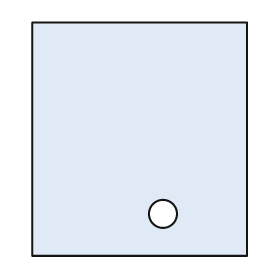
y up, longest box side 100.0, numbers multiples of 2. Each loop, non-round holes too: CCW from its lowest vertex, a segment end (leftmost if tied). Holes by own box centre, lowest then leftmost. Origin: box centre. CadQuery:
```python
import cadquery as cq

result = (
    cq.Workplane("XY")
    .moveTo(-46.0, -50.0)
    .lineTo(46.0, -50.0)
    .lineTo(46.0, 50.0)
    .lineTo(-46.0, 50.0)
    .close()
    .moveTo(10.0, -32.0)
    .circle(6.0)
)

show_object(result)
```